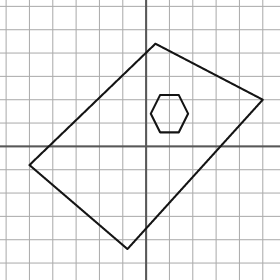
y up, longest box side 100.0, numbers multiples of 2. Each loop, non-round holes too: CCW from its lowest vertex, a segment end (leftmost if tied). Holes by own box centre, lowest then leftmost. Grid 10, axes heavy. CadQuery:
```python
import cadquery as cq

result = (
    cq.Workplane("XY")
    .moveTo(-8.0, -44.0)
    .lineTo(50.0, 20.0)
    .lineTo(4.0, 44.0)
    .lineTo(-50.0, -8.0)
    .close()
    .moveTo(6.0, 6.0)
    .lineTo(14.0, 6.0)
    .lineTo(18.0, 14.0)
    .lineTo(14.0, 22.0)
    .lineTo(6.0, 22.0)
    .lineTo(2.0, 14.0)
    .close()
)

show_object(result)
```